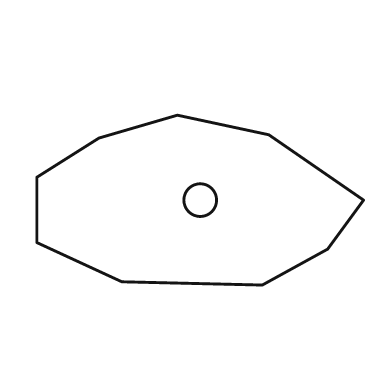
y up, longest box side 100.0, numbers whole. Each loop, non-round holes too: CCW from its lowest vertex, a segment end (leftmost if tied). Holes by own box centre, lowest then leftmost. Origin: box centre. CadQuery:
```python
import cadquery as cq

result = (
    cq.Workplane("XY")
    .moveTo(19.0, -26.0)
    .lineTo(39.0, -15.0)
    .lineTo(50.0, 0.0)
    .lineTo(21.0, 20.0)
    .lineTo(-7.0, 26.0)
    .lineTo(-31.0, 19.0)
    .lineTo(-50.0, 7.0)
    .lineTo(-50.0, -13.0)
    .lineTo(-24.0, -25.0)
    .close()
    .moveTo(0.0, 0.0)
    .circle(5.0)
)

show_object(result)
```